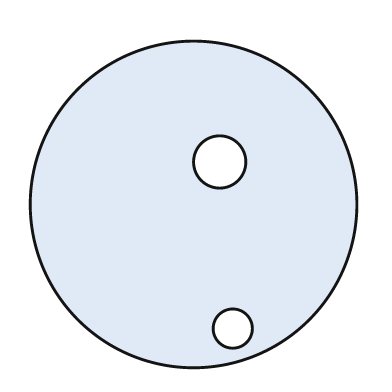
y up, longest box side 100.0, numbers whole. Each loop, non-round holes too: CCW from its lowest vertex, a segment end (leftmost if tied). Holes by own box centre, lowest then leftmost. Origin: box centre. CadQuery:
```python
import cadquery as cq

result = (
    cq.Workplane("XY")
    .moveTo(0.0, 0.0)
    .circle(50.0)
    .moveTo(12.0, -38.0)
    .circle(6.0)
    .moveTo(8.0, 13.0)
    .circle(8.0)
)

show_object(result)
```